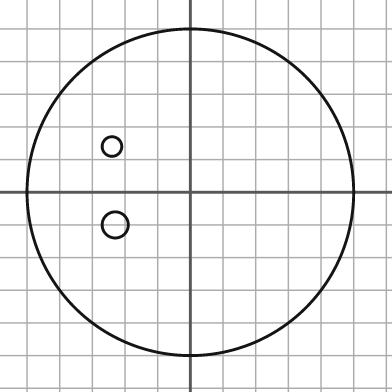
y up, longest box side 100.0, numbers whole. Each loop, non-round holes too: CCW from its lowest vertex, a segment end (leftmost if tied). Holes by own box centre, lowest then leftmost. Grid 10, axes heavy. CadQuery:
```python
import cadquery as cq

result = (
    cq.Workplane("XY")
    .moveTo(0.0, 0.0)
    .circle(50.0)
    .moveTo(-23.0, -10.0)
    .circle(4.0)
    .moveTo(-24.0, 14.0)
    .circle(3.0)
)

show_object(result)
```